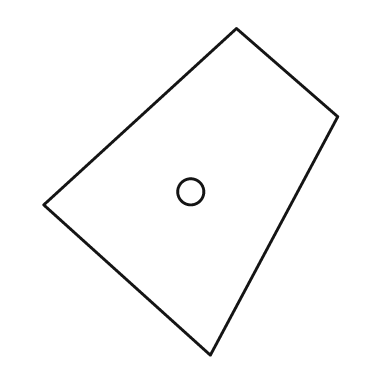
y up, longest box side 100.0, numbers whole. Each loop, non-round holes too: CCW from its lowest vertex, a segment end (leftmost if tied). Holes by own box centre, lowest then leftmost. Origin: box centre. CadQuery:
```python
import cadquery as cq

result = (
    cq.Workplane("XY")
    .moveTo(6.0, -50.0)
    .lineTo(45.0, 23.0)
    .lineTo(14.0, 50.0)
    .lineTo(-45.0, -4.0)
    .close()
    .moveTo(0.0, 0.0)
    .circle(4.0)
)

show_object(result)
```